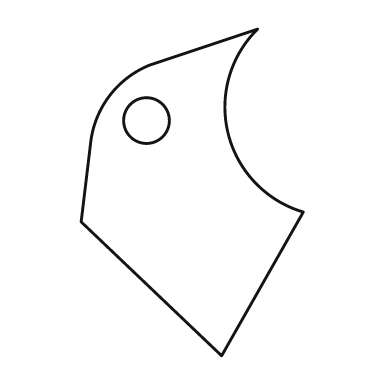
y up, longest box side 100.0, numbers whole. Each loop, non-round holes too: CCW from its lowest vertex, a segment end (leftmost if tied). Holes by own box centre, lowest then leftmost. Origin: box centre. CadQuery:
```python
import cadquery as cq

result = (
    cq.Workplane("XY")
    .moveTo(9.0, -50.0)
    .lineTo(34.0, -6.0)
    .threePointArc((11.0, 18.0), (20.0, 50.0))
    .lineTo(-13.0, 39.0)
    .threePointArc((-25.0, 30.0), (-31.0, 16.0))
    .lineTo(-34.0, -9.0)
    .close()
    .moveTo(-14.0, 22.0)
    .circle(7.0)
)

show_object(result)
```